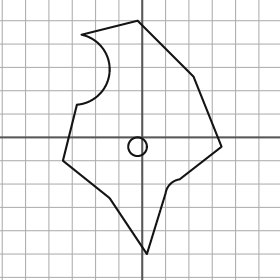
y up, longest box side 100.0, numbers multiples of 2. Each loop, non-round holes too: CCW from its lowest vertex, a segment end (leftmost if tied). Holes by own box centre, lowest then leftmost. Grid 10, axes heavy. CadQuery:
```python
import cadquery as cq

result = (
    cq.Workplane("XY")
    .moveTo(2.0, -50.0)
    .lineTo(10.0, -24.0)
    .threePointArc((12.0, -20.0), (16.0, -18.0))
    .lineTo(34.0, -4.0)
    .lineTo(22.0, 26.0)
    .lineTo(-2.0, 50.0)
    .lineTo(-26.0, 44.0)
    .threePointArc((-14.0, 28.0), (-28.0, 14.0))
    .lineTo(-34.0, -10.0)
    .lineTo(-14.0, -26.0)
    .close()
    .moveTo(-2.0, -4.0)
    .circle(4.0)
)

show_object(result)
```